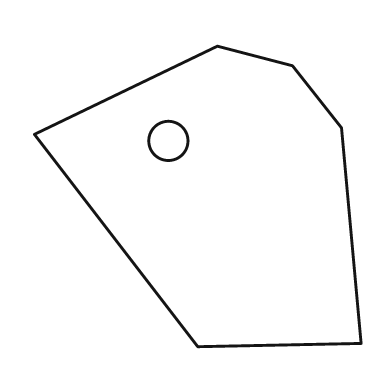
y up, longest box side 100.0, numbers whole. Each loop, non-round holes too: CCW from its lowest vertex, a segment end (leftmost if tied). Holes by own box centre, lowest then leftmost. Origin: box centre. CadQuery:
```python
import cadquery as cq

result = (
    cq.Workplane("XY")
    .moveTo(0.0, -46.0)
    .lineTo(50.0, -45.0)
    .lineTo(44.0, 21.0)
    .lineTo(29.0, 40.0)
    .lineTo(6.0, 46.0)
    .lineTo(-50.0, 19.0)
    .close()
    .moveTo(-9.0, 17.0)
    .circle(6.0)
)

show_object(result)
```